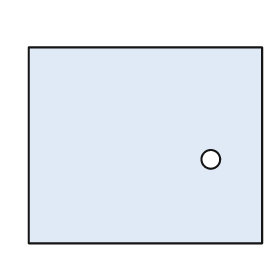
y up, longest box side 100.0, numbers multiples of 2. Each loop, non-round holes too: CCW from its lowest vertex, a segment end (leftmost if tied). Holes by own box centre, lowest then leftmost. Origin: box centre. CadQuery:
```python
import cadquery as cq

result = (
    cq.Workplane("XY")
    .moveTo(-50.0, -42.0)
    .lineTo(50.0, -42.0)
    .lineTo(50.0, 42.0)
    .lineTo(-50.0, 42.0)
    .close()
    .moveTo(28.0, -6.0)
    .circle(4.0)
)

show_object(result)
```